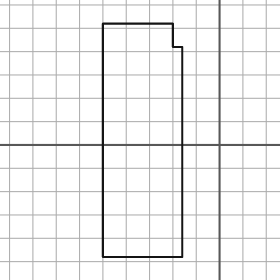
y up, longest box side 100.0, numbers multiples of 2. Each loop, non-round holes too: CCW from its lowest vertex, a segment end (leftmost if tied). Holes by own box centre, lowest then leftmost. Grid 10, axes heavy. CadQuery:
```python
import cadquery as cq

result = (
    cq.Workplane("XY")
    .moveTo(-50.0, -48.0)
    .lineTo(-16.0, -48.0)
    .lineTo(-16.0, 42.0)
    .lineTo(-20.0, 42.0)
    .lineTo(-20.0, 52.0)
    .lineTo(-50.0, 52.0)
    .close()
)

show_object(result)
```